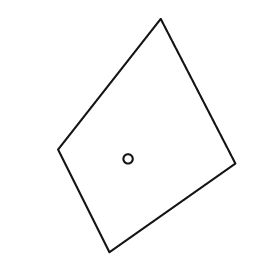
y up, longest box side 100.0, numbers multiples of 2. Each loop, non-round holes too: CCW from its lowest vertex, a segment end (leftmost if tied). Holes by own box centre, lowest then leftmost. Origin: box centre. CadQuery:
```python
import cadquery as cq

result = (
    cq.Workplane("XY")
    .moveTo(-16.0, -50.0)
    .lineTo(38.0, -12.0)
    .lineTo(6.0, 50.0)
    .lineTo(-38.0, -6.0)
    .close()
    .moveTo(-8.0, -10.0)
    .circle(2.0)
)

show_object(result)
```